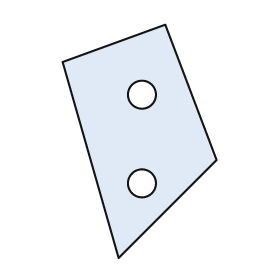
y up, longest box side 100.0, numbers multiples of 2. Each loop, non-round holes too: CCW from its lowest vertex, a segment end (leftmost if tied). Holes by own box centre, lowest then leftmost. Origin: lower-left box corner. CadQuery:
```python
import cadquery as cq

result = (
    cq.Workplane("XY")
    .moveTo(24.0, 0.0)
    .lineTo(66.0, 42.0)
    .lineTo(44.0, 100.0)
    .lineTo(0.0, 84.0)
    .close()
    .moveTo(34.0, 32.0)
    .circle(6.0)
    .moveTo(34.0, 70.0)
    .circle(6.0)
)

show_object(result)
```